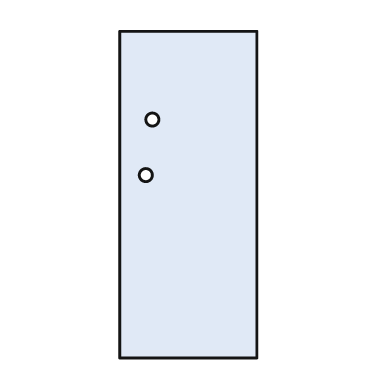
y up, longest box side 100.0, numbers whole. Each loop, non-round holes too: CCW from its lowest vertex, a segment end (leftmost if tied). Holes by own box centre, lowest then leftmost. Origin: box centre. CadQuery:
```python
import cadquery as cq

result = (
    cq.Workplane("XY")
    .moveTo(-21.0, -50.0)
    .lineTo(21.0, -50.0)
    .lineTo(21.0, 50.0)
    .lineTo(-21.0, 50.0)
    .close()
    .moveTo(-13.0, 6.0)
    .circle(2.0)
    .moveTo(-11.0, 23.0)
    .circle(2.0)
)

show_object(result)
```